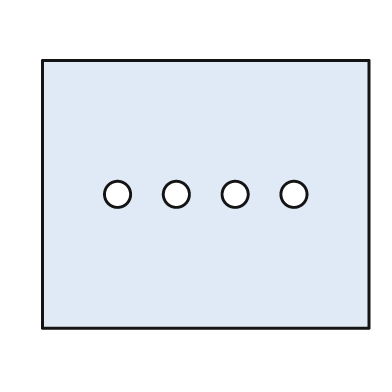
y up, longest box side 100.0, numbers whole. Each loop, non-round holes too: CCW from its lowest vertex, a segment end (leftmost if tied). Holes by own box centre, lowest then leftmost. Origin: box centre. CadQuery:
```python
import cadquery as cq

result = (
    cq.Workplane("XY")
    .moveTo(-50.0, -41.0)
    .lineTo(50.0, -41.0)
    .lineTo(50.0, 41.0)
    .lineTo(-50.0, 41.0)
    .close()
    .moveTo(-27.0, 0.0)
    .circle(4.0)
    .moveTo(-9.0, 0.0)
    .circle(4.0)
    .moveTo(9.0, 0.0)
    .circle(4.0)
    .moveTo(27.0, 0.0)
    .circle(4.0)
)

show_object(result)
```